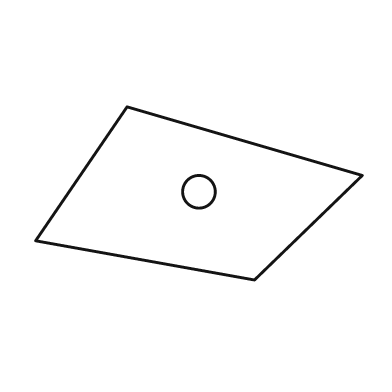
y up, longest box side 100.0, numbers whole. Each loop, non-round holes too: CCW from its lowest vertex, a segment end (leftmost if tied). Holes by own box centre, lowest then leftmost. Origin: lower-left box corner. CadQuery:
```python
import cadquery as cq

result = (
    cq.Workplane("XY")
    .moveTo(67.0, 0.0)
    .lineTo(100.0, 32.0)
    .lineTo(28.0, 53.0)
    .lineTo(0.0, 12.0)
    .close()
    .moveTo(50.0, 27.0)
    .circle(5.0)
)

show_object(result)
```